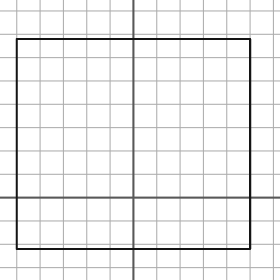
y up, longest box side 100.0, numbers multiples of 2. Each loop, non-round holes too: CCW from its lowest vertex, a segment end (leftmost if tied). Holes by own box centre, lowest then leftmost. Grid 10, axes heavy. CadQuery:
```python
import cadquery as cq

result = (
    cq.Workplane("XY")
    .moveTo(-50.0, -22.0)
    .lineTo(50.0, -22.0)
    .lineTo(50.0, 68.0)
    .lineTo(-50.0, 68.0)
    .close()
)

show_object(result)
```